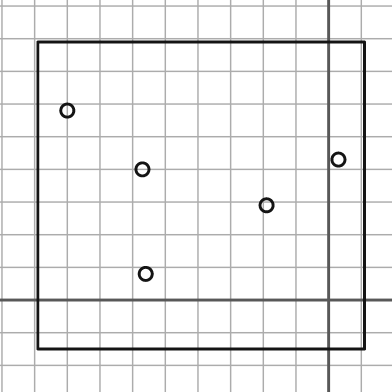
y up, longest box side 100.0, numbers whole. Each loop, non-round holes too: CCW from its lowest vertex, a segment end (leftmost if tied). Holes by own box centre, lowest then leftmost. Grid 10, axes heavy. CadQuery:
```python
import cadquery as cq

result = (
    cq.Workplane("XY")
    .moveTo(-89.0, -15.0)
    .lineTo(11.0, -15.0)
    .lineTo(11.0, 79.0)
    .lineTo(-89.0, 79.0)
    .close()
    .moveTo(-56.0, 8.0)
    .circle(2.0)
    .moveTo(-19.0, 29.0)
    .circle(2.0)
    .moveTo(-57.0, 40.0)
    .circle(2.0)
    .moveTo(3.0, 43.0)
    .circle(2.0)
    .moveTo(-80.0, 58.0)
    .circle(2.0)
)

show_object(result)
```